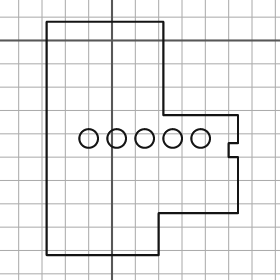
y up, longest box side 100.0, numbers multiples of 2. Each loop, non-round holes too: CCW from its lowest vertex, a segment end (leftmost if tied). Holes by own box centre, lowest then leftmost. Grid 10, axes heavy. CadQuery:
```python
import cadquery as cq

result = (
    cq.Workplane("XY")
    .moveTo(-28.0, -92.0)
    .lineTo(20.0, -92.0)
    .lineTo(20.0, -74.0)
    .lineTo(54.0, -74.0)
    .lineTo(54.0, -50.0)
    .lineTo(50.0, -50.0)
    .lineTo(50.0, -44.0)
    .lineTo(54.0, -44.0)
    .lineTo(54.0, -32.0)
    .lineTo(22.0, -32.0)
    .lineTo(22.0, 8.0)
    .lineTo(-28.0, 8.0)
    .close()
    .moveTo(-10.0, -42.0)
    .circle(4.0)
    .moveTo(2.0, -42.0)
    .circle(4.0)
    .moveTo(14.0, -42.0)
    .circle(4.0)
    .moveTo(26.0, -42.0)
    .circle(4.0)
    .moveTo(38.0, -42.0)
    .circle(4.0)
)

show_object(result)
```